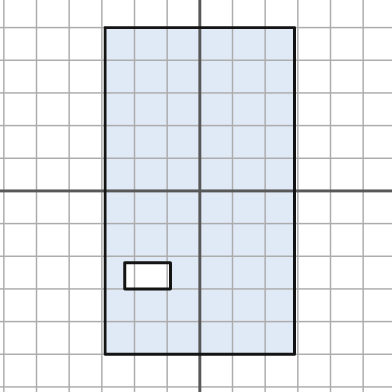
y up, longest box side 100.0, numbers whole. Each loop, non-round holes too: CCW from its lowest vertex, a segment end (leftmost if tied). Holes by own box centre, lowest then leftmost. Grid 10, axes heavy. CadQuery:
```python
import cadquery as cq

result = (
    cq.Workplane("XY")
    .moveTo(-29.0, -50.0)
    .lineTo(29.0, -50.0)
    .lineTo(29.0, 50.0)
    .lineTo(-29.0, 50.0)
    .close()
    .moveTo(-23.0, -30.0)
    .lineTo(-9.0, -30.0)
    .lineTo(-9.0, -22.0)
    .lineTo(-23.0, -22.0)
    .close()
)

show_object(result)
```